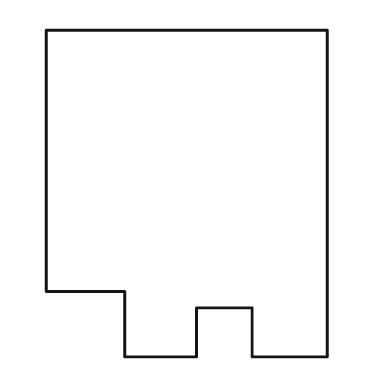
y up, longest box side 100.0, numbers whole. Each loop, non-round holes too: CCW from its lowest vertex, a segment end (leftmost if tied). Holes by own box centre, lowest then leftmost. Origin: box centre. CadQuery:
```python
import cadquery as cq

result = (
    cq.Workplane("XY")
    .moveTo(-19.0, -50.0)
    .lineTo(3.0, -50.0)
    .lineTo(3.0, -35.0)
    .lineTo(20.0, -35.0)
    .lineTo(20.0, -50.0)
    .lineTo(43.0, -50.0)
    .lineTo(43.0, 50.0)
    .lineTo(-43.0, 50.0)
    .lineTo(-43.0, -30.0)
    .lineTo(-19.0, -30.0)
    .close()
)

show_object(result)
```